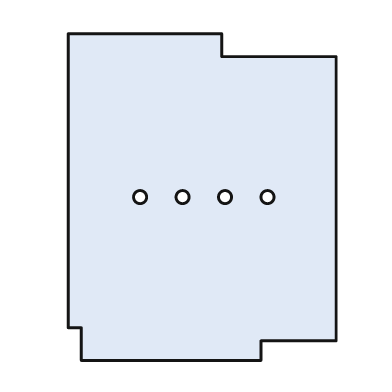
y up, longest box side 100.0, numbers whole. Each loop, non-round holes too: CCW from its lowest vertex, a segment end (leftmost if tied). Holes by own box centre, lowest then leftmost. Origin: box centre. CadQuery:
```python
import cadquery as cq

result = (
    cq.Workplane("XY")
    .moveTo(-37.0, -50.0)
    .lineTo(18.0, -50.0)
    .lineTo(18.0, -44.0)
    .lineTo(41.0, -44.0)
    .lineTo(41.0, 43.0)
    .lineTo(6.0, 43.0)
    .lineTo(6.0, 50.0)
    .lineTo(-41.0, 50.0)
    .lineTo(-41.0, -40.0)
    .lineTo(-37.0, -40.0)
    .close()
    .moveTo(-19.0, 0.0)
    .circle(2.0)
    .moveTo(-6.0, 0.0)
    .circle(2.0)
    .moveTo(7.0, 0.0)
    .circle(2.0)
    .moveTo(20.0, 0.0)
    .circle(2.0)
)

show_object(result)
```